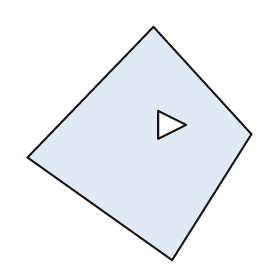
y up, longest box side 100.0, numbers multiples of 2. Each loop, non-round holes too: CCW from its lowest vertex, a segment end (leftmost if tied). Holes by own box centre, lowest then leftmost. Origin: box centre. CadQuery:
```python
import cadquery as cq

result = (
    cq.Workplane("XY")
    .moveTo(14.0, -50.0)
    .lineTo(48.0, 4.0)
    .lineTo(6.0, 50.0)
    .lineTo(-48.0, -6.0)
    .close()
    .moveTo(8.0, 2.0)
    .lineTo(20.0, 8.0)
    .lineTo(8.0, 14.0)
    .close()
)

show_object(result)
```